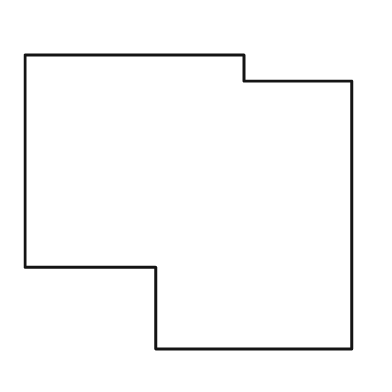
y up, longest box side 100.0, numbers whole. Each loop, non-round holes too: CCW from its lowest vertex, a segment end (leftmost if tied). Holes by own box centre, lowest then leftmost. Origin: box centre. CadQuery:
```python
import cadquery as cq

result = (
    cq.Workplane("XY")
    .moveTo(-10.0, -45.0)
    .lineTo(50.0, -45.0)
    .lineTo(50.0, 37.0)
    .lineTo(17.0, 37.0)
    .lineTo(17.0, 45.0)
    .lineTo(-50.0, 45.0)
    .lineTo(-50.0, -20.0)
    .lineTo(-10.0, -20.0)
    .close()
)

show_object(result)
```